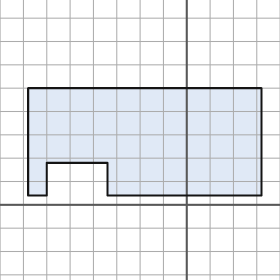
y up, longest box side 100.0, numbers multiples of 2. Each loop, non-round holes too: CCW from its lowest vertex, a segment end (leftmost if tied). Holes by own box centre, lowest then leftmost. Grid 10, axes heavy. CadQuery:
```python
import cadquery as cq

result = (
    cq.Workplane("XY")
    .moveTo(-68.0, 4.0)
    .lineTo(-60.0, 4.0)
    .lineTo(-60.0, 18.0)
    .lineTo(-34.0, 18.0)
    .lineTo(-34.0, 4.0)
    .lineTo(32.0, 4.0)
    .lineTo(32.0, 50.0)
    .lineTo(-68.0, 50.0)
    .close()
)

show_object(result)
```